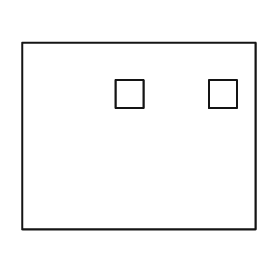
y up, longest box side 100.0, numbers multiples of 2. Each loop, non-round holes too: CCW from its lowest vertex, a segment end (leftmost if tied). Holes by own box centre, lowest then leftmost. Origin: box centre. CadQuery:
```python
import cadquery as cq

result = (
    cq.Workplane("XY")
    .moveTo(-50.0, -40.0)
    .lineTo(50.0, -40.0)
    .lineTo(50.0, 40.0)
    .lineTo(-50.0, 40.0)
    .close()
    .moveTo(-10.0, 12.0)
    .lineTo(2.0, 12.0)
    .lineTo(2.0, 24.0)
    .lineTo(-10.0, 24.0)
    .close()
    .moveTo(30.0, 12.0)
    .lineTo(42.0, 12.0)
    .lineTo(42.0, 24.0)
    .lineTo(30.0, 24.0)
    .close()
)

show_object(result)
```